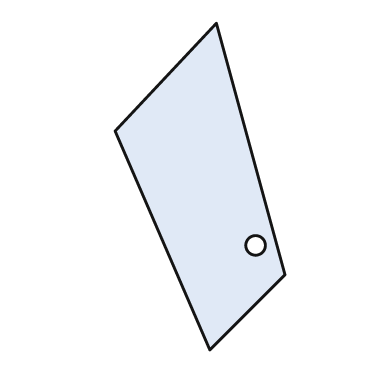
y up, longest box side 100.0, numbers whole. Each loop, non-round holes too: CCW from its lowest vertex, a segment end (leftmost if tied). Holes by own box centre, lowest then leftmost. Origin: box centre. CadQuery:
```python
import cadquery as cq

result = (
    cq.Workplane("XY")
    .moveTo(3.0, -50.0)
    .lineTo(26.0, -27.0)
    .lineTo(5.0, 50.0)
    .lineTo(-26.0, 17.0)
    .close()
    .moveTo(17.0, -18.0)
    .circle(3.0)
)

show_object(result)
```